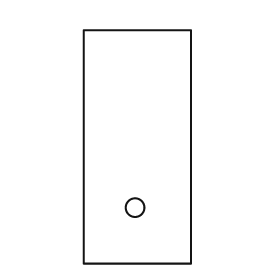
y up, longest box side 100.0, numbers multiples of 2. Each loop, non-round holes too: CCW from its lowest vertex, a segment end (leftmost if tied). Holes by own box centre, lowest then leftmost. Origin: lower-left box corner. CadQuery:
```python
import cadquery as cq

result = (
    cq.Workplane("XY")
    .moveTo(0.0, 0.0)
    .lineTo(46.0, 0.0)
    .lineTo(46.0, 100.0)
    .lineTo(0.0, 100.0)
    .close()
    .moveTo(22.0, 24.0)
    .circle(4.0)
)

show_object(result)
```